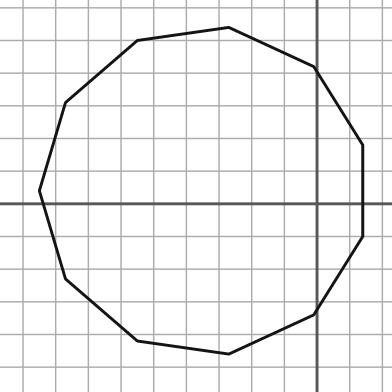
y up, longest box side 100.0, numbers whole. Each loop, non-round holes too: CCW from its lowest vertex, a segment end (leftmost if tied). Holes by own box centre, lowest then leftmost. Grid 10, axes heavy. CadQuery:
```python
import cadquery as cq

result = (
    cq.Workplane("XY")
    .moveTo(-27.0, -46.0)
    .lineTo(-1.0, -34.0)
    .lineTo(14.0, -10.0)
    .lineTo(14.0, 18.0)
    .lineTo(-1.0, 42.0)
    .lineTo(-27.0, 54.0)
    .lineTo(-55.0, 50.0)
    .lineTo(-77.0, 31.0)
    .lineTo(-85.0, 4.0)
    .lineTo(-77.0, -23.0)
    .lineTo(-55.0, -42.0)
    .close()
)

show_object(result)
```